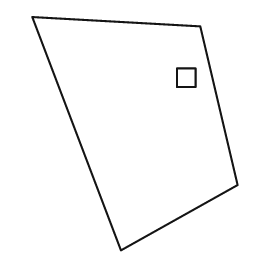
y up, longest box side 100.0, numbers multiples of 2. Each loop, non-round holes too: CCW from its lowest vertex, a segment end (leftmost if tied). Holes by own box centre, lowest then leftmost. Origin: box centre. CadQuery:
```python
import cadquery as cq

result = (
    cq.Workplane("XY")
    .moveTo(-6.0, -50.0)
    .lineTo(44.0, -22.0)
    .lineTo(28.0, 46.0)
    .lineTo(-44.0, 50.0)
    .close()
    .moveTo(18.0, 20.0)
    .lineTo(26.0, 20.0)
    .lineTo(26.0, 28.0)
    .lineTo(18.0, 28.0)
    .close()
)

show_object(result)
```